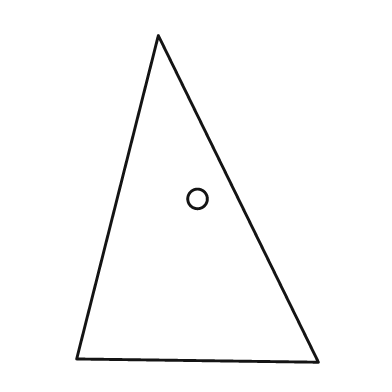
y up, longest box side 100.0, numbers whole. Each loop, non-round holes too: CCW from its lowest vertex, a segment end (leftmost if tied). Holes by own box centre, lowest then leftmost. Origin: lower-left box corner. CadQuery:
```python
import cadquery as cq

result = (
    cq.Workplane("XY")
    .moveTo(74.0, 0.0)
    .lineTo(25.0, 100.0)
    .lineTo(0.0, 1.0)
    .close()
    .moveTo(37.0, 50.0)
    .circle(3.0)
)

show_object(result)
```